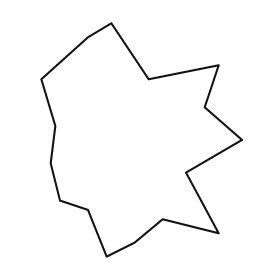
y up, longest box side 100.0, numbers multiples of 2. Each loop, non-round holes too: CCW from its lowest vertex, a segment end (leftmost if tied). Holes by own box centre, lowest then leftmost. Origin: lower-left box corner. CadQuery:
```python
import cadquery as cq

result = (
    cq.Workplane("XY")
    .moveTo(28.0, 0.0)
    .lineTo(40.0, 6.0)
    .lineTo(52.0, 16.0)
    .lineTo(76.0, 10.0)
    .lineTo(62.0, 36.0)
    .lineTo(86.0, 50.0)
    .lineTo(70.0, 64.0)
    .lineTo(76.0, 82.0)
    .lineTo(46.0, 76.0)
    .lineTo(30.0, 100.0)
    .lineTo(20.0, 94.0)
    .lineTo(0.0, 76.0)
    .lineTo(6.0, 56.0)
    .lineTo(4.0, 40.0)
    .lineTo(8.0, 24.0)
    .lineTo(20.0, 20.0)
    .close()
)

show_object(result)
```